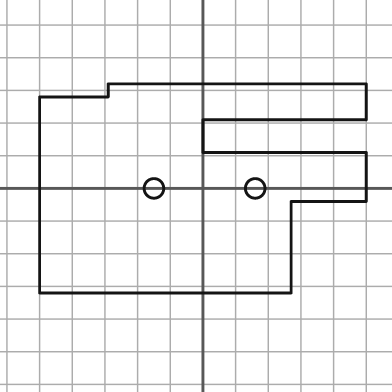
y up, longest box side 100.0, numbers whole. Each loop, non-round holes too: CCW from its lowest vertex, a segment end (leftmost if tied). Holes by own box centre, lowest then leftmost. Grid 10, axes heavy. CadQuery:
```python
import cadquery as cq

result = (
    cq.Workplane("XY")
    .moveTo(-50.0, -32.0)
    .lineTo(27.0, -32.0)
    .lineTo(27.0, -4.0)
    .lineTo(50.0, -4.0)
    .lineTo(50.0, 11.0)
    .lineTo(0.0, 11.0)
    .lineTo(0.0, 21.0)
    .lineTo(50.0, 21.0)
    .lineTo(50.0, 32.0)
    .lineTo(-29.0, 32.0)
    .lineTo(-29.0, 28.0)
    .lineTo(-50.0, 28.0)
    .close()
    .moveTo(-15.0, 0.0)
    .circle(3.0)
    .moveTo(16.0, 0.0)
    .circle(3.0)
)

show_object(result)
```